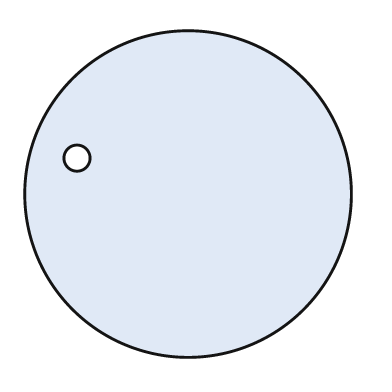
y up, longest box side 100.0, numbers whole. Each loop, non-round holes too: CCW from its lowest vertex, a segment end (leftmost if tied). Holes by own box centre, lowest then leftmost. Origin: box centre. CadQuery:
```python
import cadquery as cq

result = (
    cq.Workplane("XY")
    .moveTo(0.0, 0.0)
    .circle(50.0)
    .moveTo(-34.0, 11.0)
    .circle(4.0)
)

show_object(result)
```